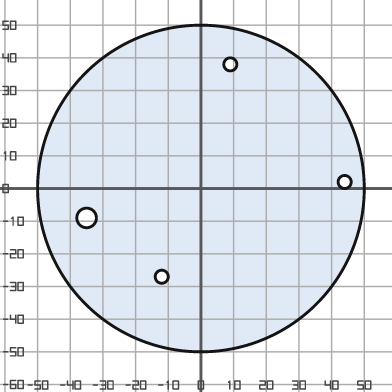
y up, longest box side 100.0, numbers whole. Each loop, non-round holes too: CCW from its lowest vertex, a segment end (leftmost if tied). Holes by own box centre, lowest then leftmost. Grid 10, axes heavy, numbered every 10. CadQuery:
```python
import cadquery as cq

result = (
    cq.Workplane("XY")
    .moveTo(0.0, 0.0)
    .circle(50.0)
    .moveTo(-12.0, -27.0)
    .circle(2.0)
    .moveTo(-35.0, -9.0)
    .circle(3.0)
    .moveTo(44.0, 2.0)
    .circle(2.0)
    .moveTo(9.0, 38.0)
    .circle(2.0)
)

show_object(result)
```